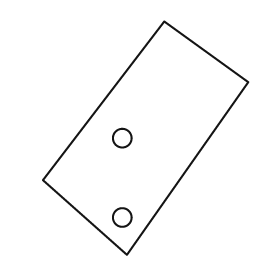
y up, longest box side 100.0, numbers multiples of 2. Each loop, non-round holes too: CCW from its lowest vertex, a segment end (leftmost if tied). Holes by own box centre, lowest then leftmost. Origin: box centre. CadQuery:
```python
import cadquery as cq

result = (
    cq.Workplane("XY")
    .moveTo(-8.0, -50.0)
    .lineTo(44.0, 24.0)
    .lineTo(8.0, 50.0)
    .lineTo(-44.0, -18.0)
    .close()
    .moveTo(-10.0, -34.0)
    .circle(4.0)
    .moveTo(-10.0, 0.0)
    .circle(4.0)
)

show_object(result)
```